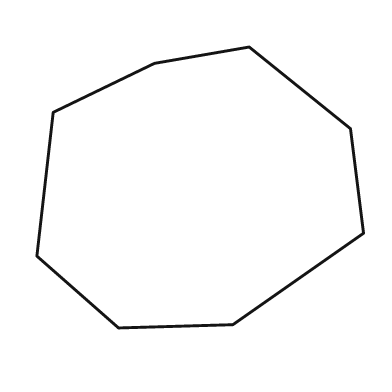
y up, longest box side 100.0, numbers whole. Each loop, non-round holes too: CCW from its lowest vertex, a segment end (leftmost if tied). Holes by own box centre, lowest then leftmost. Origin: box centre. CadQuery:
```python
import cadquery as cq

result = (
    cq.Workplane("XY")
    .moveTo(-25.0, -43.0)
    .lineTo(10.0, -42.0)
    .lineTo(50.0, -14.0)
    .lineTo(46.0, 18.0)
    .lineTo(15.0, 43.0)
    .lineTo(-14.0, 38.0)
    .lineTo(-45.0, 23.0)
    .lineTo(-50.0, -21.0)
    .close()
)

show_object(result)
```